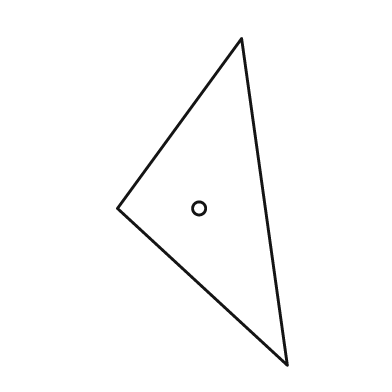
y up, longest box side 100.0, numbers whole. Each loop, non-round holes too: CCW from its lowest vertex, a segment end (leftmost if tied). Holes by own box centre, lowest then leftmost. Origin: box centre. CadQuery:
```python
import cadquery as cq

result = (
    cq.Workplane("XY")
    .moveTo(26.0, -50.0)
    .lineTo(12.0, 50.0)
    .lineTo(-26.0, -2.0)
    .close()
    .moveTo(-1.0, -2.0)
    .circle(2.0)
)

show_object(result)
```